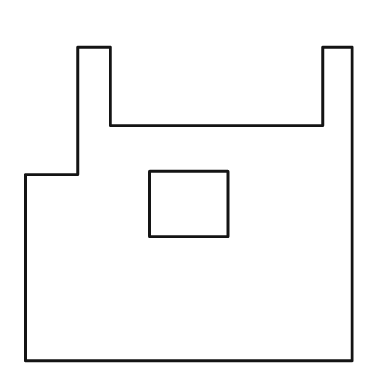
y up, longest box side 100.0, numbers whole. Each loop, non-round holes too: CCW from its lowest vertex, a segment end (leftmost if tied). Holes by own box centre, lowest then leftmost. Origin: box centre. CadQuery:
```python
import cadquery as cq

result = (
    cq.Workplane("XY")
    .moveTo(-50.0, -48.0)
    .lineTo(50.0, -48.0)
    .lineTo(50.0, 48.0)
    .lineTo(41.0, 48.0)
    .lineTo(41.0, 24.0)
    .lineTo(-24.0, 24.0)
    .lineTo(-24.0, 48.0)
    .lineTo(-34.0, 48.0)
    .lineTo(-34.0, 9.0)
    .lineTo(-50.0, 9.0)
    .close()
    .moveTo(-12.0, -10.0)
    .lineTo(12.0, -10.0)
    .lineTo(12.0, 10.0)
    .lineTo(-12.0, 10.0)
    .close()
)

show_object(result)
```